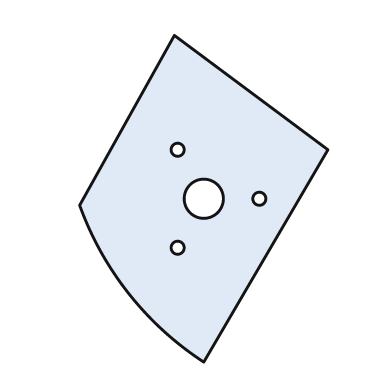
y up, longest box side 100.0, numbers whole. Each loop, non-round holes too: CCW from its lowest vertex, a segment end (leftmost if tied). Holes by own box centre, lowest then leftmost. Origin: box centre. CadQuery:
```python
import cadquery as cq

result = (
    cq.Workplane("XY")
    .moveTo(0.0, -50.0)
    .lineTo(38.0, 15.0)
    .lineTo(-9.0, 50.0)
    .lineTo(-38.0, -2.0)
    .threePointArc((-23.0, -29.0), (0.0, -50.0))
    .close()
    .moveTo(-8.0, -15.0)
    .circle(2.0)
    .moveTo(0.0, 0.0)
    .circle(6.0)
    .moveTo(17.0, 0.0)
    .circle(2.0)
    .moveTo(-8.0, 15.0)
    .circle(2.0)
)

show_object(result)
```